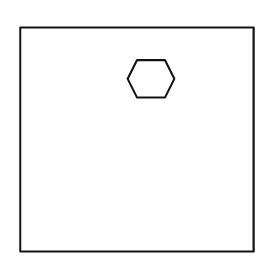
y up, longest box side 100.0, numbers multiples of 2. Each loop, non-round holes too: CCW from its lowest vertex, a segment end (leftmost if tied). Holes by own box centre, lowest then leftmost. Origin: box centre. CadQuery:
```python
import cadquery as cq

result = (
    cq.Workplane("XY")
    .moveTo(-50.0, -48.0)
    .lineTo(50.0, -48.0)
    .lineTo(50.0, 48.0)
    .lineTo(-50.0, 48.0)
    .close()
    .moveTo(0.0, 18.0)
    .lineTo(12.0, 18.0)
    .lineTo(16.0, 26.0)
    .lineTo(12.0, 34.0)
    .lineTo(0.0, 34.0)
    .lineTo(-4.0, 26.0)
    .close()
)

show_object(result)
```